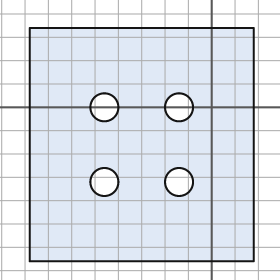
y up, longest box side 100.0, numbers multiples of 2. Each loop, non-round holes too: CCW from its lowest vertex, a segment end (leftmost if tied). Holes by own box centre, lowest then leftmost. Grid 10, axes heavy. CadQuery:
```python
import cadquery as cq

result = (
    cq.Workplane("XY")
    .moveTo(-78.0, -66.0)
    .lineTo(18.0, -66.0)
    .lineTo(18.0, 34.0)
    .lineTo(-78.0, 34.0)
    .close()
    .moveTo(-46.0, -32.0)
    .circle(6.0)
    .moveTo(-14.0, -32.0)
    .circle(6.0)
    .moveTo(-46.0, 0.0)
    .circle(6.0)
    .moveTo(-14.0, 0.0)
    .circle(6.0)
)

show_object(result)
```